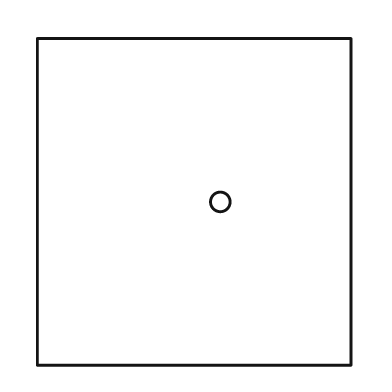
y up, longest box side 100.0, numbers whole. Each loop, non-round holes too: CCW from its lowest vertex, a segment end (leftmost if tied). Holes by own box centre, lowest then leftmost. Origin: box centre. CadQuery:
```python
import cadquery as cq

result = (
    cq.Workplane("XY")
    .moveTo(-48.0, -50.0)
    .lineTo(48.0, -50.0)
    .lineTo(48.0, 50.0)
    .lineTo(-48.0, 50.0)
    .close()
    .moveTo(8.0, 0.0)
    .circle(3.0)
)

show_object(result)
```